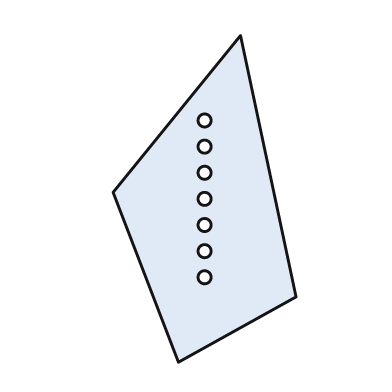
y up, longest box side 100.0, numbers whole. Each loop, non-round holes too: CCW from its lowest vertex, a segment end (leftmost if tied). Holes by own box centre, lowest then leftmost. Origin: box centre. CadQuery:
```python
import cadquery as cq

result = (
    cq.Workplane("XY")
    .moveTo(-8.0, -50.0)
    .lineTo(28.0, -30.0)
    .lineTo(11.0, 50.0)
    .lineTo(-28.0, 2.0)
    .close()
    .moveTo(0.0, -24.0)
    .circle(2.0)
    .moveTo(0.0, -16.0)
    .circle(2.0)
    .moveTo(0.0, -8.0)
    .circle(2.0)
    .moveTo(0.0, 0.0)
    .circle(2.0)
    .moveTo(0.0, 8.0)
    .circle(2.0)
    .moveTo(0.0, 16.0)
    .circle(2.0)
    .moveTo(0.0, 24.0)
    .circle(2.0)
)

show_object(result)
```